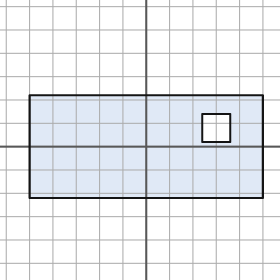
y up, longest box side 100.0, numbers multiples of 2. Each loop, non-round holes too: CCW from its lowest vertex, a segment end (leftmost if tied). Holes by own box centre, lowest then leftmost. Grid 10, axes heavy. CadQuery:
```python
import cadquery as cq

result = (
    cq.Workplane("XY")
    .moveTo(-50.0, -22.0)
    .lineTo(50.0, -22.0)
    .lineTo(50.0, 22.0)
    .lineTo(-50.0, 22.0)
    .close()
    .moveTo(24.0, 2.0)
    .lineTo(36.0, 2.0)
    .lineTo(36.0, 14.0)
    .lineTo(24.0, 14.0)
    .close()
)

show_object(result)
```